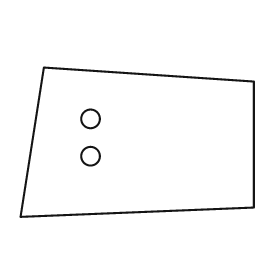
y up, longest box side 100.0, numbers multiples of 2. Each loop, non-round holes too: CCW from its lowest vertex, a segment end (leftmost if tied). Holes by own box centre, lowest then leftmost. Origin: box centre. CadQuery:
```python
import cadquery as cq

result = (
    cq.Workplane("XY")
    .moveTo(-50.0, -32.0)
    .lineTo(50.0, -28.0)
    .lineTo(50.0, 26.0)
    .lineTo(-40.0, 32.0)
    .close()
    .moveTo(-20.0, -6.0)
    .circle(4.0)
    .moveTo(-20.0, 10.0)
    .circle(4.0)
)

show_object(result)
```